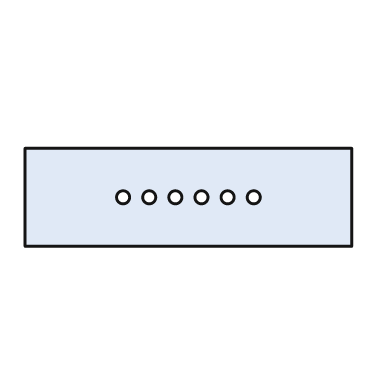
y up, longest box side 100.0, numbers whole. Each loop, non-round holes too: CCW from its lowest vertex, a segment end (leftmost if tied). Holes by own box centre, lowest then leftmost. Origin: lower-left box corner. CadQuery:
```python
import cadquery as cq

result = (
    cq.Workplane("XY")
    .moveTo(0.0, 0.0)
    .lineTo(100.0, 0.0)
    .lineTo(100.0, 30.0)
    .lineTo(0.0, 30.0)
    .close()
    .moveTo(30.0, 15.0)
    .circle(2.0)
    .moveTo(38.0, 15.0)
    .circle(2.0)
    .moveTo(46.0, 15.0)
    .circle(2.0)
    .moveTo(54.0, 15.0)
    .circle(2.0)
    .moveTo(62.0, 15.0)
    .circle(2.0)
    .moveTo(70.0, 15.0)
    .circle(2.0)
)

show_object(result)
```